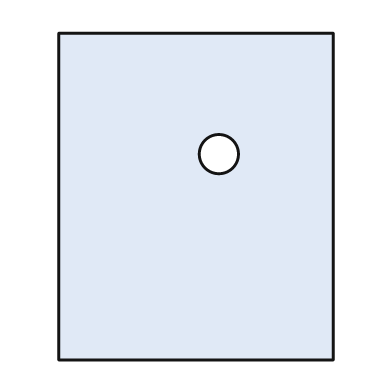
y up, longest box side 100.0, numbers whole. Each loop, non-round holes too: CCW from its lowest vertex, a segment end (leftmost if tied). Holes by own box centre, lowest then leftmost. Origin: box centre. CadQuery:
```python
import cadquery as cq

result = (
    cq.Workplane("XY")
    .moveTo(-42.0, -50.0)
    .lineTo(42.0, -50.0)
    .lineTo(42.0, 50.0)
    .lineTo(-42.0, 50.0)
    .close()
    .moveTo(7.0, 13.0)
    .circle(6.0)
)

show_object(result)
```